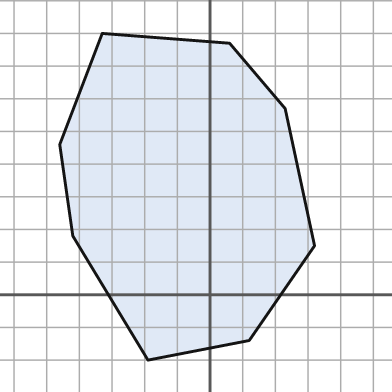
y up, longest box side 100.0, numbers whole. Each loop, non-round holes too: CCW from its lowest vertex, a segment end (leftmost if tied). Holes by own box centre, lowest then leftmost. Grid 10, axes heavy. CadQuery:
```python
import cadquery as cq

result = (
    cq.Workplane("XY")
    .moveTo(-19.0, -20.0)
    .lineTo(12.0, -14.0)
    .lineTo(32.0, 15.0)
    .lineTo(23.0, 57.0)
    .lineTo(6.0, 77.0)
    .lineTo(-33.0, 80.0)
    .lineTo(-46.0, 46.0)
    .lineTo(-42.0, 18.0)
    .close()
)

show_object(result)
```